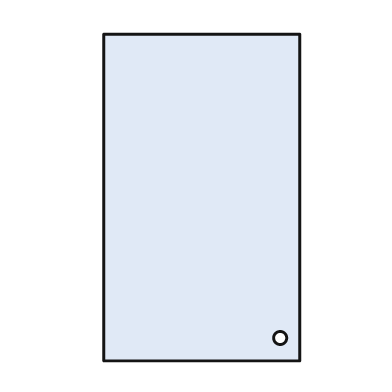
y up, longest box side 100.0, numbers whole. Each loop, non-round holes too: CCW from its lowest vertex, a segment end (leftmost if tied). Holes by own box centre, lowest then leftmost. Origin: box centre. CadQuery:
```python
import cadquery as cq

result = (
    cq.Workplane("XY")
    .moveTo(-30.0, -50.0)
    .lineTo(30.0, -50.0)
    .lineTo(30.0, 50.0)
    .lineTo(-30.0, 50.0)
    .close()
    .moveTo(24.0, -43.0)
    .circle(2.0)
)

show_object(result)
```